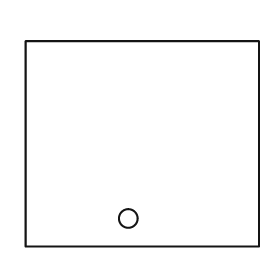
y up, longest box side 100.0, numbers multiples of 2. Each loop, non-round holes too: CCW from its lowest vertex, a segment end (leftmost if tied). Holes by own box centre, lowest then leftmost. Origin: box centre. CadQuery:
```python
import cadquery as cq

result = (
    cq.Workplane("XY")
    .moveTo(-50.0, -44.0)
    .lineTo(50.0, -44.0)
    .lineTo(50.0, 44.0)
    .lineTo(-50.0, 44.0)
    .close()
    .moveTo(-6.0, -32.0)
    .circle(4.0)
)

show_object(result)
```